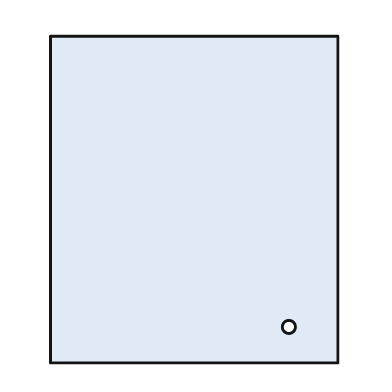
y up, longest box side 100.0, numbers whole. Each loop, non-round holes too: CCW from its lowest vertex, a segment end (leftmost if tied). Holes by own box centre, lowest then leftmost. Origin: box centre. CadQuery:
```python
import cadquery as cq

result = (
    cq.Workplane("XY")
    .moveTo(-44.0, -50.0)
    .lineTo(44.0, -50.0)
    .lineTo(44.0, 50.0)
    .lineTo(-44.0, 50.0)
    .close()
    .moveTo(29.0, -39.0)
    .circle(2.0)
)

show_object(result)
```